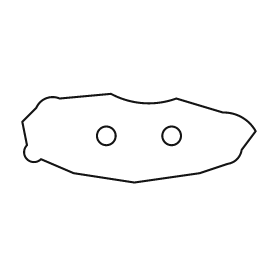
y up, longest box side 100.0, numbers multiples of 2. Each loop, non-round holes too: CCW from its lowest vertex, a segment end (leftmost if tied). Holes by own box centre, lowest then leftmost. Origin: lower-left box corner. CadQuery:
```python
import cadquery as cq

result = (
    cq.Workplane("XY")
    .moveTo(48.0, 0.0)
    .lineTo(76.0, 4.0)
    .lineTo(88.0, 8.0)
    .threePointArc((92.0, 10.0), (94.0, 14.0))
    .lineTo(100.0, 22.0)
    .threePointArc((94.0, 28.0), (86.0, 30.0))
    .lineTo(66.0, 36.0)
    .threePointArc((52.0, 34.0), (38.0, 38.0))
    .lineTo(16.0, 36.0)
    .threePointArc((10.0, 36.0), (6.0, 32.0))
    .lineTo(0.0, 26.0)
    .lineTo(2.0, 16.0)
    .threePointArc((2.0, 10.0), (8.0, 10.0))
    .lineTo(22.0, 4.0)
    .close()
    .moveTo(36.0, 20.0)
    .circle(4.0)
    .moveTo(64.0, 20.0)
    .circle(4.0)
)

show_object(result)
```